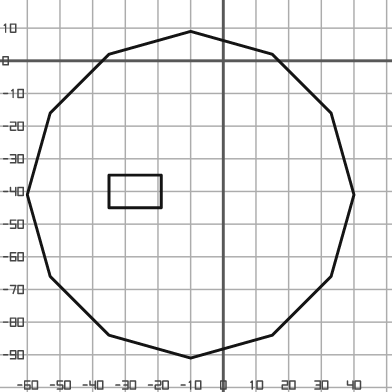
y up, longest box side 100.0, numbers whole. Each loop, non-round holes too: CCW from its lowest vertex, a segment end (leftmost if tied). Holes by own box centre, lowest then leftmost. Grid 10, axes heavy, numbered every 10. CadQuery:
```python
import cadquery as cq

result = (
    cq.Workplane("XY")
    .moveTo(-10.0, -91.0)
    .lineTo(15.0, -84.0)
    .lineTo(33.0, -66.0)
    .lineTo(40.0, -41.0)
    .lineTo(33.0, -16.0)
    .lineTo(15.0, 2.0)
    .lineTo(-10.0, 9.0)
    .lineTo(-35.0, 2.0)
    .lineTo(-53.0, -16.0)
    .lineTo(-60.0, -41.0)
    .lineTo(-53.0, -66.0)
    .lineTo(-35.0, -84.0)
    .close()
    .moveTo(-35.0, -45.0)
    .lineTo(-19.0, -45.0)
    .lineTo(-19.0, -35.0)
    .lineTo(-35.0, -35.0)
    .close()
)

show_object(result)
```